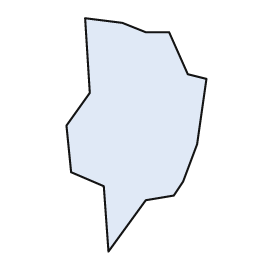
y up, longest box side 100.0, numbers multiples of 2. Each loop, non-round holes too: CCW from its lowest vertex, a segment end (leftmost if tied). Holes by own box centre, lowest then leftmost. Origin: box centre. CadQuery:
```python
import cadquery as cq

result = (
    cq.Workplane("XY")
    .moveTo(-12.0, -50.0)
    .lineTo(4.0, -28.0)
    .lineTo(16.0, -26.0)
    .lineTo(20.0, -20.0)
    .lineTo(26.0, -4.0)
    .lineTo(30.0, 24.0)
    .lineTo(22.0, 26.0)
    .lineTo(14.0, 44.0)
    .lineTo(4.0, 44.0)
    .lineTo(-6.0, 48.0)
    .lineTo(-22.0, 50.0)
    .lineTo(-20.0, 18.0)
    .lineTo(-30.0, 4.0)
    .lineTo(-28.0, -16.0)
    .lineTo(-14.0, -22.0)
    .close()
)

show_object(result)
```